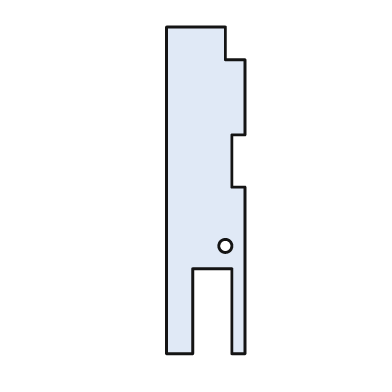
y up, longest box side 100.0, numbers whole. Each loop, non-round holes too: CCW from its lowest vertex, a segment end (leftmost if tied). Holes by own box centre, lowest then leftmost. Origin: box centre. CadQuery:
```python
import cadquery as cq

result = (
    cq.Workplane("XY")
    .moveTo(-12.0, -50.0)
    .lineTo(-4.0, -50.0)
    .lineTo(-4.0, -24.0)
    .lineTo(8.0, -24.0)
    .lineTo(8.0, -50.0)
    .lineTo(12.0, -50.0)
    .lineTo(12.0, 1.0)
    .lineTo(8.0, 1.0)
    .lineTo(8.0, 17.0)
    .lineTo(12.0, 17.0)
    .lineTo(12.0, 40.0)
    .lineTo(6.0, 40.0)
    .lineTo(6.0, 50.0)
    .lineTo(-12.0, 50.0)
    .close()
    .moveTo(6.0, -17.0)
    .circle(2.0)
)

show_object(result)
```